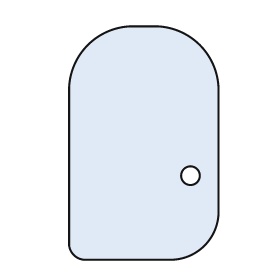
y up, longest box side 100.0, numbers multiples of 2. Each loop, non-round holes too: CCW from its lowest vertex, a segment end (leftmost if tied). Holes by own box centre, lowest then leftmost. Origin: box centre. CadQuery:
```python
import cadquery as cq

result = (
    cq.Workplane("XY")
    .moveTo(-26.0, -50.0)
    .lineTo(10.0, -50.0)
    .threePointArc((26.0, -44.0), (32.0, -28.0))
    .lineTo(32.0, 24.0)
    .threePointArc((24.0, 42.0), (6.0, 50.0))
    .lineTo(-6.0, 50.0)
    .threePointArc((-24.0, 42.0), (-32.0, 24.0))
    .lineTo(-32.0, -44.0)
    .threePointArc((-30.0, -48.0), (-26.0, -50.0))
    .close()
    .moveTo(20.0, -14.0)
    .circle(4.0)
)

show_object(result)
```